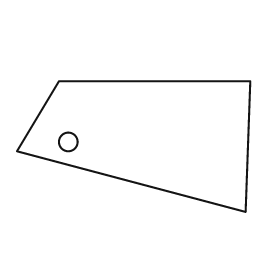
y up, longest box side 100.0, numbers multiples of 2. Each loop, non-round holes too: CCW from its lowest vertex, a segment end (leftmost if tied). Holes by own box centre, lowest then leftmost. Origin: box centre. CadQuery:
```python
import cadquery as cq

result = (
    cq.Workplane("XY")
    .moveTo(48.0, -28.0)
    .lineTo(50.0, 28.0)
    .lineTo(-32.0, 28.0)
    .lineTo(-50.0, -2.0)
    .close()
    .moveTo(-28.0, 2.0)
    .circle(4.0)
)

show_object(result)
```